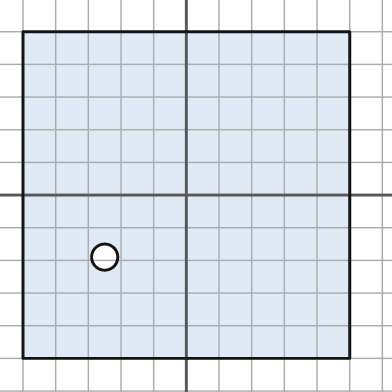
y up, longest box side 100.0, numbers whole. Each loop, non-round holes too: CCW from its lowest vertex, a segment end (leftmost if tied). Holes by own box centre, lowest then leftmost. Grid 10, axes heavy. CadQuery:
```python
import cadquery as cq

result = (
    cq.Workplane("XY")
    .moveTo(-50.0, -50.0)
    .lineTo(50.0, -50.0)
    .lineTo(50.0, 50.0)
    .lineTo(-50.0, 50.0)
    .close()
    .moveTo(-25.0, -19.0)
    .circle(4.0)
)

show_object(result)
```